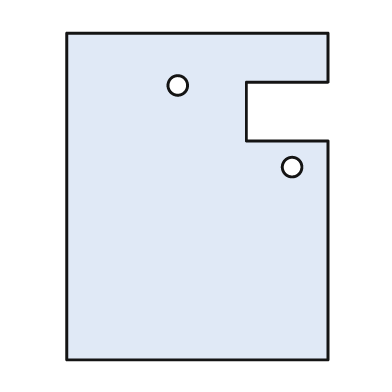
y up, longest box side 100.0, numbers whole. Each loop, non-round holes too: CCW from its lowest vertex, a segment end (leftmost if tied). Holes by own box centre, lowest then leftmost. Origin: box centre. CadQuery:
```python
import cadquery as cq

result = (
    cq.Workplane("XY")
    .moveTo(-40.0, -50.0)
    .lineTo(40.0, -50.0)
    .lineTo(40.0, 17.0)
    .lineTo(15.0, 17.0)
    .lineTo(15.0, 35.0)
    .lineTo(40.0, 35.0)
    .lineTo(40.0, 50.0)
    .lineTo(-40.0, 50.0)
    .close()
    .moveTo(29.0, 9.0)
    .circle(3.0)
    .moveTo(-6.0, 34.0)
    .circle(3.0)
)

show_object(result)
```